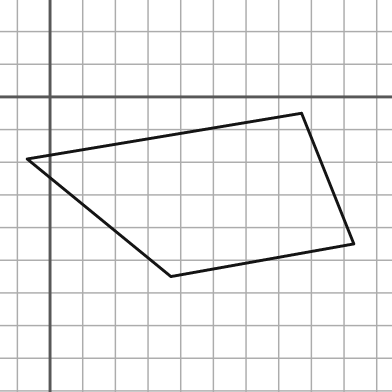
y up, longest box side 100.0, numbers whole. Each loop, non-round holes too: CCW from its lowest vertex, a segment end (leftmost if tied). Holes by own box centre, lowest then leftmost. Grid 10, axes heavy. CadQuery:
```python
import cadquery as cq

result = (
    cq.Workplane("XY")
    .moveTo(37.0, -55.0)
    .lineTo(93.0, -45.0)
    .lineTo(77.0, -5.0)
    .lineTo(-7.0, -19.0)
    .close()
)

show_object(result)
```